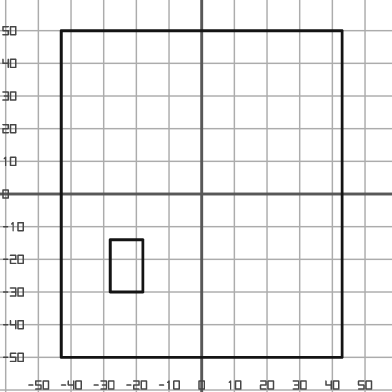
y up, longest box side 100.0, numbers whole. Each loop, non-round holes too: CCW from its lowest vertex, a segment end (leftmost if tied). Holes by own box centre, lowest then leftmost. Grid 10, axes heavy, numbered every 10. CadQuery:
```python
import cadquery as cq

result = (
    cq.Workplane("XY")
    .moveTo(-43.0, -50.0)
    .lineTo(43.0, -50.0)
    .lineTo(43.0, 50.0)
    .lineTo(-43.0, 50.0)
    .close()
    .moveTo(-28.0, -30.0)
    .lineTo(-18.0, -30.0)
    .lineTo(-18.0, -14.0)
    .lineTo(-28.0, -14.0)
    .close()
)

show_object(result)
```